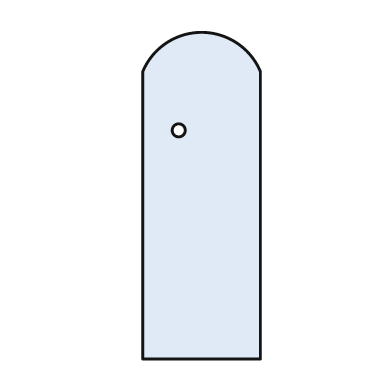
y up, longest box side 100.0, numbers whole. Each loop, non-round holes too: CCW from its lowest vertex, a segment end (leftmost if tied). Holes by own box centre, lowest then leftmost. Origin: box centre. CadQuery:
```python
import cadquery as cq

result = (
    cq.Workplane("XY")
    .moveTo(-18.0, -50.0)
    .lineTo(18.0, -50.0)
    .lineTo(18.0, 38.0)
    .threePointArc((0.0, 50.0), (-18.0, 38.0))
    .close()
    .moveTo(-7.0, 20.0)
    .circle(2.0)
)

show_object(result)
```